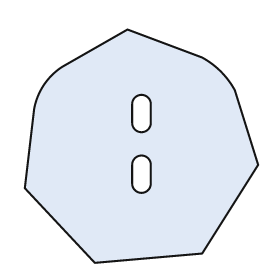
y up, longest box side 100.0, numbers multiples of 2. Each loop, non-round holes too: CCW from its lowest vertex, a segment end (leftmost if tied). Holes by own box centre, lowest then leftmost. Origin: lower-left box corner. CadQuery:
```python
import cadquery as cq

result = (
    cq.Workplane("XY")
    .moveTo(30.0, 0.0)
    .lineTo(76.0, 4.0)
    .lineTo(100.0, 42.0)
    .lineTo(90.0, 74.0)
    .threePointArc((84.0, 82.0), (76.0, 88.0))
    .lineTo(44.0, 100.0)
    .lineTo(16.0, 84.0)
    .threePointArc((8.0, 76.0), (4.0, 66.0))
    .lineTo(0.0, 32.0)
    .close()
    .moveTo(46.0, 34.0)
    .threePointArc((50.0, 30.0), (54.0, 34.0))
    .lineTo(54.0, 42.0)
    .threePointArc((50.0, 46.0), (46.0, 42.0))
    .close()
    .moveTo(46.0, 60.0)
    .threePointArc((50.0, 56.0), (54.0, 60.0))
    .lineTo(54.0, 68.0)
    .threePointArc((50.0, 72.0), (46.0, 68.0))
    .close()
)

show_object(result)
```